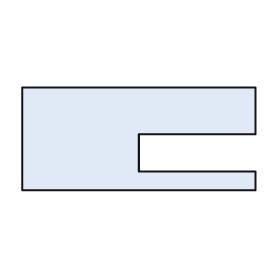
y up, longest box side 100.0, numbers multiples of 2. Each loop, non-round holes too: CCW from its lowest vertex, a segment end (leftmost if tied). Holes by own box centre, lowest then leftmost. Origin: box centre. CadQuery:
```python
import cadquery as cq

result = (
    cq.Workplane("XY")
    .moveTo(-50.0, -22.0)
    .lineTo(50.0, -22.0)
    .lineTo(50.0, -14.0)
    .lineTo(0.0, -14.0)
    .lineTo(0.0, 2.0)
    .lineTo(50.0, 2.0)
    .lineTo(50.0, 22.0)
    .lineTo(-50.0, 22.0)
    .close()
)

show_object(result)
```